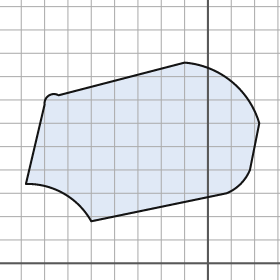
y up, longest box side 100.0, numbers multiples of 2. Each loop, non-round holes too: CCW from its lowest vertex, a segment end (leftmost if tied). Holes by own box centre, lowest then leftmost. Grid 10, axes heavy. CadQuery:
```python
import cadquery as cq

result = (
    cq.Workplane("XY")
    .moveTo(-50.0, 18.0)
    .lineTo(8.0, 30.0)
    .threePointArc((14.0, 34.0), (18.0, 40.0))
    .lineTo(22.0, 60.0)
    .threePointArc((10.0, 78.0), (-10.0, 86.0))
    .lineTo(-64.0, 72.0)
    .threePointArc((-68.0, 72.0), (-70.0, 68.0))
    .lineTo(-78.0, 34.0)
    .threePointArc((-62.0, 30.0), (-50.0, 18.0))
    .close()
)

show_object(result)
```